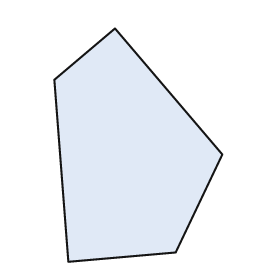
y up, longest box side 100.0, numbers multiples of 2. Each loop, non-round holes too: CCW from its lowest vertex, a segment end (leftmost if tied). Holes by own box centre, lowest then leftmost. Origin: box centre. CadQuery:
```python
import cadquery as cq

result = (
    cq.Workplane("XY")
    .moveTo(-30.0, -50.0)
    .lineTo(16.0, -46.0)
    .lineTo(36.0, -4.0)
    .lineTo(-10.0, 50.0)
    .lineTo(-36.0, 28.0)
    .close()
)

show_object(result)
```